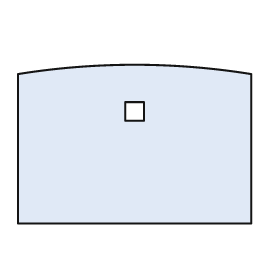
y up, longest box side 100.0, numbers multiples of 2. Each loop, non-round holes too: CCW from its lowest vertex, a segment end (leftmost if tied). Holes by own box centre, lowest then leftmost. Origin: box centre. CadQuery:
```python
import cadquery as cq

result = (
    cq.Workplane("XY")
    .moveTo(-50.0, -34.0)
    .lineTo(50.0, -34.0)
    .lineTo(50.0, 30.0)
    .threePointArc((0.0, 34.0), (-50.0, 30.0))
    .close()
    .moveTo(-4.0, 10.0)
    .lineTo(4.0, 10.0)
    .lineTo(4.0, 18.0)
    .lineTo(-4.0, 18.0)
    .close()
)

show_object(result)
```